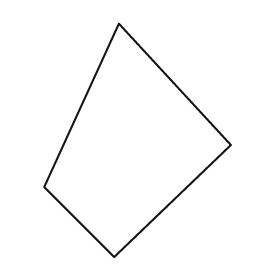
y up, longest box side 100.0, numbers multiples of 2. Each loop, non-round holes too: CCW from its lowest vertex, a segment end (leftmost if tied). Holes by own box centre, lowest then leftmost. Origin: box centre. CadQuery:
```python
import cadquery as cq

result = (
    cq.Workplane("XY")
    .moveTo(-10.0, -50.0)
    .lineTo(40.0, -2.0)
    .lineTo(-8.0, 50.0)
    .lineTo(-40.0, -20.0)
    .close()
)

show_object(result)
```